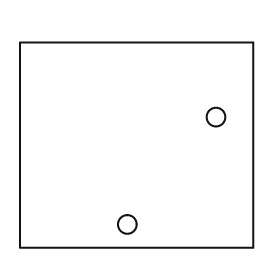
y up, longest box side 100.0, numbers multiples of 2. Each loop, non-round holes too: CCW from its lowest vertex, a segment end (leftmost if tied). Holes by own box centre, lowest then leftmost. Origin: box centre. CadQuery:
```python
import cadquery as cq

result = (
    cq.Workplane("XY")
    .moveTo(-50.0, -44.0)
    .lineTo(50.0, -44.0)
    .lineTo(50.0, 44.0)
    .lineTo(-50.0, 44.0)
    .close()
    .moveTo(-4.0, -34.0)
    .circle(4.0)
    .moveTo(34.0, 12.0)
    .circle(4.0)
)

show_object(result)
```